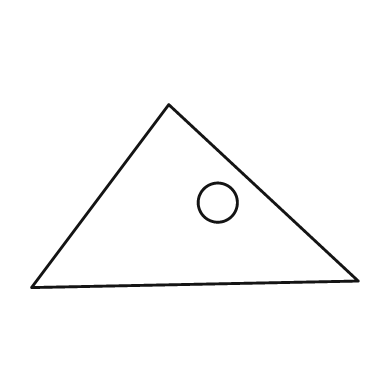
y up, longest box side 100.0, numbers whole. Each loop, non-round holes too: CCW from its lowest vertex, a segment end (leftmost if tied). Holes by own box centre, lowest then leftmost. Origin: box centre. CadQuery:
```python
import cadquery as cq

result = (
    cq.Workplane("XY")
    .moveTo(-50.0, -28.0)
    .lineTo(50.0, -26.0)
    .lineTo(-8.0, 28.0)
    .close()
    .moveTo(7.0, -2.0)
    .circle(6.0)
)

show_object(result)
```